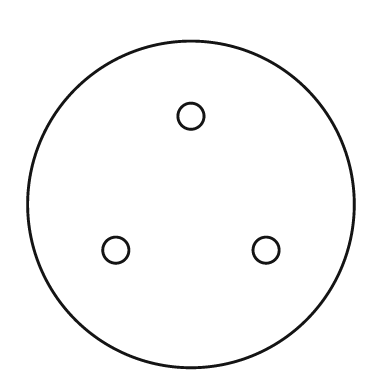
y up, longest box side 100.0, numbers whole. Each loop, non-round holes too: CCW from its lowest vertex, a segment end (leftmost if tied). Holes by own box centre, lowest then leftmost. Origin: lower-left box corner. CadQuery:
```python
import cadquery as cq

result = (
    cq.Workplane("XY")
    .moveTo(50.0, 50.0)
    .circle(50.0)
    .moveTo(27.0, 36.0)
    .circle(4.0)
    .moveTo(73.0, 36.0)
    .circle(4.0)
    .moveTo(50.0, 77.0)
    .circle(4.0)
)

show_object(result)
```